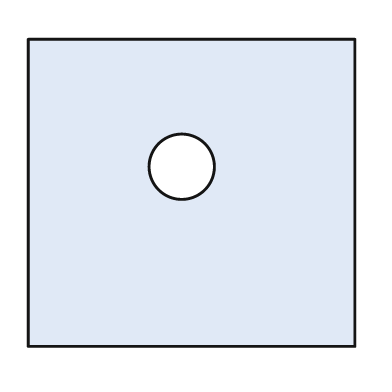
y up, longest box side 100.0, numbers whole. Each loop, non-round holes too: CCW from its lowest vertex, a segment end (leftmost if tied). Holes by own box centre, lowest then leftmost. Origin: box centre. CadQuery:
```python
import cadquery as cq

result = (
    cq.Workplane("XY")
    .moveTo(-50.0, -47.0)
    .lineTo(50.0, -47.0)
    .lineTo(50.0, 47.0)
    .lineTo(-50.0, 47.0)
    .close()
    .moveTo(-3.0, 8.0)
    .circle(10.0)
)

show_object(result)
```